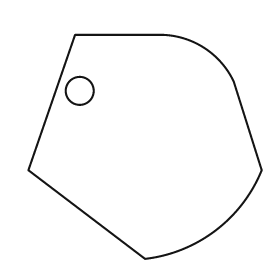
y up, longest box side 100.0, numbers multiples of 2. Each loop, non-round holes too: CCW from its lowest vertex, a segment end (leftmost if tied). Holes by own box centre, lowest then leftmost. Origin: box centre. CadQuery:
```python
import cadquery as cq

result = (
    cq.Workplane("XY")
    .moveTo(0.0, -48.0)
    .threePointArc((30.0, -36.0), (50.0, -10.0))
    .lineTo(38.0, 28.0)
    .threePointArc((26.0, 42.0), (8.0, 48.0))
    .lineTo(-30.0, 48.0)
    .lineTo(-50.0, -10.0)
    .close()
    .moveTo(-28.0, 24.0)
    .circle(6.0)
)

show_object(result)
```